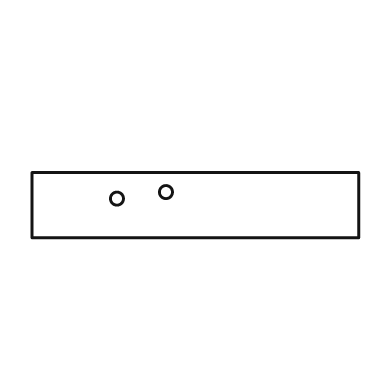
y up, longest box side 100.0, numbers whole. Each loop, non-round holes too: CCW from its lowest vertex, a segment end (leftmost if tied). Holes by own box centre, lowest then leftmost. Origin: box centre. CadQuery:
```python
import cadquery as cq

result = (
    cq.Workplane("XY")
    .moveTo(-50.0, -10.0)
    .lineTo(50.0, -10.0)
    .lineTo(50.0, 10.0)
    .lineTo(-50.0, 10.0)
    .close()
    .moveTo(-24.0, 2.0)
    .circle(2.0)
    .moveTo(-9.0, 4.0)
    .circle(2.0)
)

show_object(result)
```